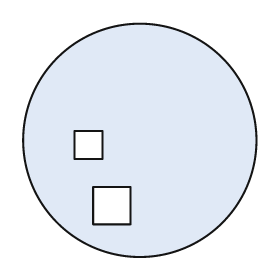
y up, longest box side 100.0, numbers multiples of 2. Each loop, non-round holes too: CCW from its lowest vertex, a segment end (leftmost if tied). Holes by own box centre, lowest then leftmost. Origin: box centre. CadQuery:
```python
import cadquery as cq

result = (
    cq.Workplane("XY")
    .moveTo(0.0, 0.0)
    .circle(50.0)
    .moveTo(-20.0, -36.0)
    .lineTo(-4.0, -36.0)
    .lineTo(-4.0, -20.0)
    .lineTo(-20.0, -20.0)
    .close()
    .moveTo(-28.0, -8.0)
    .lineTo(-16.0, -8.0)
    .lineTo(-16.0, 4.0)
    .lineTo(-28.0, 4.0)
    .close()
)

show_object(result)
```